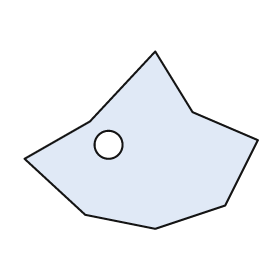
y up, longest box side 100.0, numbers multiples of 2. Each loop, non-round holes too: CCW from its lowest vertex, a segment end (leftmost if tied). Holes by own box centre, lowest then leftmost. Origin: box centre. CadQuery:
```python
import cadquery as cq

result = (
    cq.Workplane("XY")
    .moveTo(6.0, -38.0)
    .lineTo(36.0, -28.0)
    .lineTo(50.0, 0.0)
    .lineTo(22.0, 12.0)
    .lineTo(6.0, 38.0)
    .lineTo(-22.0, 8.0)
    .lineTo(-50.0, -8.0)
    .lineTo(-24.0, -32.0)
    .close()
    .moveTo(-14.0, -2.0)
    .circle(6.0)
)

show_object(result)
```